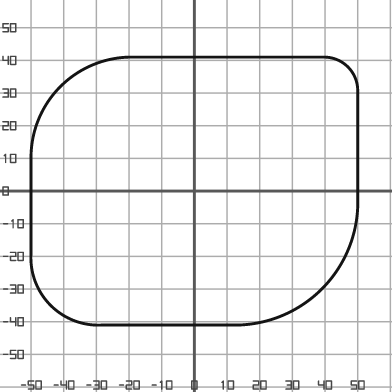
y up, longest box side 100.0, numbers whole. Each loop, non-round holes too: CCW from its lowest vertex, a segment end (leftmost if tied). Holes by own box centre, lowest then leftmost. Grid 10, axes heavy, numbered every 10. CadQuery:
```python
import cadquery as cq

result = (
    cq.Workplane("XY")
    .moveTo(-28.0, -41.0)
    .lineTo(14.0, -41.0)
    .threePointArc((39.0, -30.0), (50.0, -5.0))
    .lineTo(50.0, 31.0)
    .threePointArc((47.0, 38.0), (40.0, 41.0))
    .lineTo(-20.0, 41.0)
    .threePointArc((-41.0, 32.0), (-50.0, 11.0))
    .lineTo(-50.0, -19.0)
    .threePointArc((-44.0, -35.0), (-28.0, -41.0))
    .close()
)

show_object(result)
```